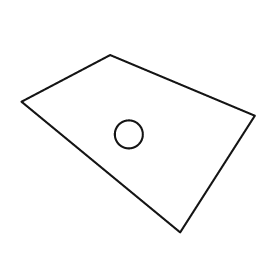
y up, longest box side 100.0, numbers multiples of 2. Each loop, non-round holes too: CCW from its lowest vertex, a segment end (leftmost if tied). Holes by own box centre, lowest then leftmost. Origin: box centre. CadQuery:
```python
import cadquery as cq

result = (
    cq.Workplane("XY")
    .moveTo(18.0, -38.0)
    .lineTo(50.0, 12.0)
    .lineTo(-12.0, 38.0)
    .lineTo(-50.0, 18.0)
    .close()
    .moveTo(-4.0, 4.0)
    .circle(6.0)
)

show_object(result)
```